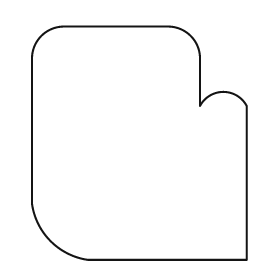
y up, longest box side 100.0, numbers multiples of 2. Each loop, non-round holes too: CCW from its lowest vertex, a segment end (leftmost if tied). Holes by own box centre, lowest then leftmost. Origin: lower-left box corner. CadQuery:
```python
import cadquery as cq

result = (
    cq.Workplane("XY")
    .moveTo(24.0, 0.0)
    .lineTo(92.0, 0.0)
    .lineTo(92.0, 66.0)
    .threePointArc((82.0, 72.0), (72.0, 66.0))
    .lineTo(72.0, 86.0)
    .threePointArc((68.0, 96.0), (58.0, 100.0))
    .lineTo(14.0, 100.0)
    .threePointArc((4.0, 96.0), (0.0, 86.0))
    .lineTo(0.0, 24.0)
    .threePointArc((8.0, 8.0), (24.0, 0.0))
    .close()
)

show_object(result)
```